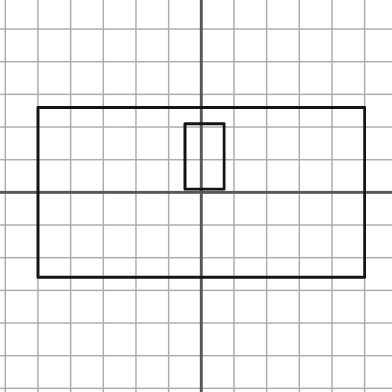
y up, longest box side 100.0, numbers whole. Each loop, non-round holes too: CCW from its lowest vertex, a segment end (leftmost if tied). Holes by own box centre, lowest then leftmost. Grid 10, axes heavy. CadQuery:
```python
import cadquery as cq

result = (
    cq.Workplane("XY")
    .moveTo(-50.0, -26.0)
    .lineTo(50.0, -26.0)
    .lineTo(50.0, 26.0)
    .lineTo(-50.0, 26.0)
    .close()
    .moveTo(-5.0, 1.0)
    .lineTo(7.0, 1.0)
    .lineTo(7.0, 21.0)
    .lineTo(-5.0, 21.0)
    .close()
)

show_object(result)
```